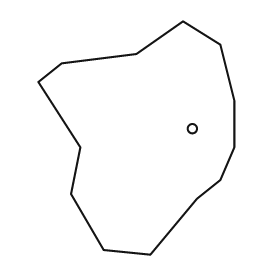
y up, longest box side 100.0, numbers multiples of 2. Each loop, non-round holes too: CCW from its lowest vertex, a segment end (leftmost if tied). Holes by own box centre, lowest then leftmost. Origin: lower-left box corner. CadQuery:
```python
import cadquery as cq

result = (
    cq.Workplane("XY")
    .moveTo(48.0, 0.0)
    .lineTo(68.0, 24.0)
    .lineTo(78.0, 32.0)
    .lineTo(84.0, 46.0)
    .lineTo(84.0, 66.0)
    .lineTo(78.0, 90.0)
    .lineTo(62.0, 100.0)
    .lineTo(42.0, 86.0)
    .lineTo(10.0, 82.0)
    .lineTo(0.0, 74.0)
    .lineTo(18.0, 46.0)
    .lineTo(14.0, 26.0)
    .lineTo(28.0, 2.0)
    .close()
    .moveTo(66.0, 54.0)
    .circle(2.0)
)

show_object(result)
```